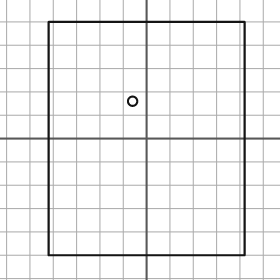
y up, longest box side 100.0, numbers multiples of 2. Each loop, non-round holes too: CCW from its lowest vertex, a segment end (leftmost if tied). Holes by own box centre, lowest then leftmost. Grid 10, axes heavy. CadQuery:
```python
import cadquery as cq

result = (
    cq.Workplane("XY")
    .moveTo(-42.0, -50.0)
    .lineTo(42.0, -50.0)
    .lineTo(42.0, 50.0)
    .lineTo(-42.0, 50.0)
    .close()
    .moveTo(-6.0, 16.0)
    .circle(2.0)
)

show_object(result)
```